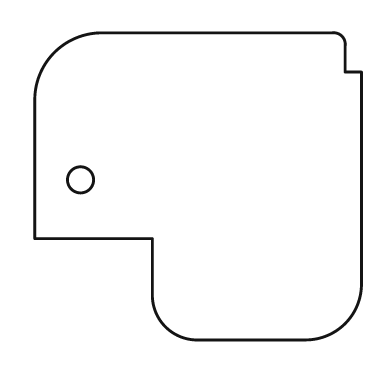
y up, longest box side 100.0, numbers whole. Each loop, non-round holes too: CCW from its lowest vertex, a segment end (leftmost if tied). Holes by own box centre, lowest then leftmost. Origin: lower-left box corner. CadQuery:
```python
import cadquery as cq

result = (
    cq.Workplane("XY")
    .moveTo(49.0, 0.0)
    .lineTo(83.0, 0.0)
    .threePointArc((95.0, 5.0), (100.0, 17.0))
    .lineTo(100.0, 82.0)
    .lineTo(95.0, 82.0)
    .lineTo(95.0, 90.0)
    .threePointArc((94.0, 93.0), (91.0, 94.0))
    .lineTo(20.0, 94.0)
    .threePointArc((6.0, 88.0), (0.0, 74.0))
    .lineTo(0.0, 31.0)
    .lineTo(36.0, 31.0)
    .lineTo(36.0, 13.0)
    .threePointArc((40.0, 4.0), (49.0, 0.0))
    .close()
    .moveTo(14.0, 49.0)
    .circle(4.0)
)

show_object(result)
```